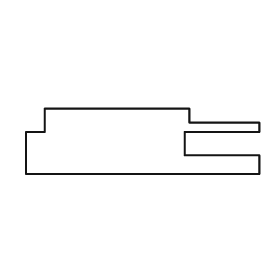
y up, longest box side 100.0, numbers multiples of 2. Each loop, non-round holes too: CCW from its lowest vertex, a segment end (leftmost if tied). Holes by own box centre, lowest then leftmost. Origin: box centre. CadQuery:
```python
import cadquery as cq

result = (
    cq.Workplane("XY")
    .moveTo(-50.0, -14.0)
    .lineTo(50.0, -14.0)
    .lineTo(50.0, -6.0)
    .lineTo(18.0, -6.0)
    .lineTo(18.0, 4.0)
    .lineTo(50.0, 4.0)
    .lineTo(50.0, 8.0)
    .lineTo(20.0, 8.0)
    .lineTo(20.0, 14.0)
    .lineTo(-42.0, 14.0)
    .lineTo(-42.0, 4.0)
    .lineTo(-50.0, 4.0)
    .close()
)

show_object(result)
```